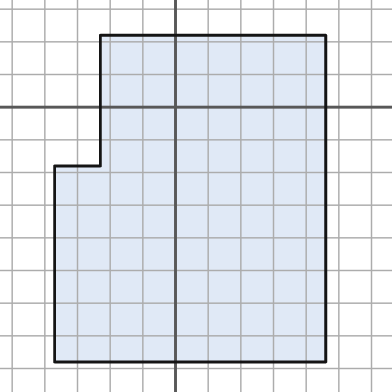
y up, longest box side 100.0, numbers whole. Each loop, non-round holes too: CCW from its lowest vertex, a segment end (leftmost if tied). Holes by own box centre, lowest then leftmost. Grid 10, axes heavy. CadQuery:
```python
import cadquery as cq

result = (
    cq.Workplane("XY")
    .moveTo(-37.0, -78.0)
    .lineTo(46.0, -78.0)
    .lineTo(46.0, 22.0)
    .lineTo(-23.0, 22.0)
    .lineTo(-23.0, -18.0)
    .lineTo(-37.0, -18.0)
    .close()
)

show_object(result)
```